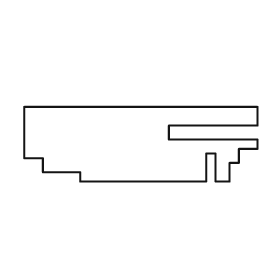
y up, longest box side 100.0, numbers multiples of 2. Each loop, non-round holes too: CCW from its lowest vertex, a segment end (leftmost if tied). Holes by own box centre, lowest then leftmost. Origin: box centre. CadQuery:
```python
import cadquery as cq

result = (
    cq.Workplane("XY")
    .moveTo(-26.0, -16.0)
    .lineTo(28.0, -16.0)
    .lineTo(28.0, -4.0)
    .lineTo(32.0, -4.0)
    .lineTo(32.0, -16.0)
    .lineTo(38.0, -16.0)
    .lineTo(38.0, -8.0)
    .lineTo(42.0, -8.0)
    .lineTo(42.0, -2.0)
    .lineTo(50.0, -2.0)
    .lineTo(50.0, 2.0)
    .lineTo(12.0, 2.0)
    .lineTo(12.0, 8.0)
    .lineTo(50.0, 8.0)
    .lineTo(50.0, 16.0)
    .lineTo(-50.0, 16.0)
    .lineTo(-50.0, -6.0)
    .lineTo(-42.0, -6.0)
    .lineTo(-42.0, -12.0)
    .lineTo(-26.0, -12.0)
    .close()
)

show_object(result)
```